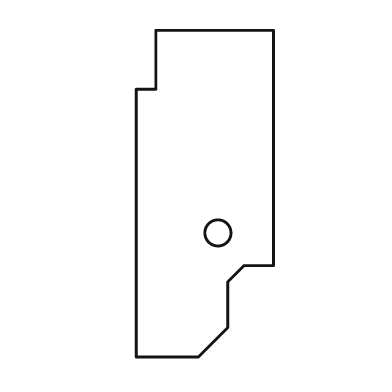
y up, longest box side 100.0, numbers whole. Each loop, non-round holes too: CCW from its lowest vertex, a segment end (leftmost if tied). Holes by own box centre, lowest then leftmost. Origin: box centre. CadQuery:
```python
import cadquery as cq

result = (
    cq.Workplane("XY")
    .moveTo(-21.0, -50.0)
    .lineTo(-2.0, -50.0)
    .lineTo(7.0, -41.0)
    .lineTo(7.0, -27.0)
    .lineTo(12.0, -22.0)
    .lineTo(21.0, -22.0)
    .lineTo(21.0, 50.0)
    .lineTo(-15.0, 50.0)
    .lineTo(-15.0, 32.0)
    .lineTo(-21.0, 32.0)
    .close()
    .moveTo(4.0, -12.0)
    .circle(4.0)
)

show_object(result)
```